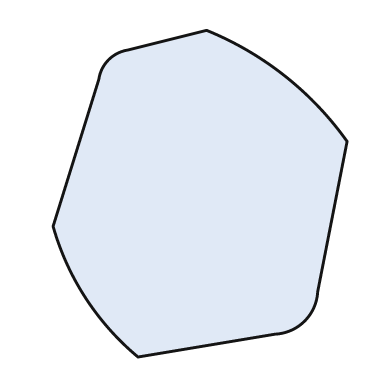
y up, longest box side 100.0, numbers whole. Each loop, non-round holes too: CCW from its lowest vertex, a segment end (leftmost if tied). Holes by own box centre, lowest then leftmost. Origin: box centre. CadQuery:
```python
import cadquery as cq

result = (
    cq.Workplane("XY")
    .moveTo(-19.0, -50.0)
    .lineTo(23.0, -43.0)
    .threePointArc((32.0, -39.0), (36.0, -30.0))
    .lineTo(45.0, 16.0)
    .threePointArc((26.0, 36.0), (2.0, 50.0))
    .lineTo(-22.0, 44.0)
    .threePointArc((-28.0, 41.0), (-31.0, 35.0))
    .lineTo(-45.0, -10.0)
    .threePointArc((-35.0, -32.0), (-19.0, -50.0))
    .close()
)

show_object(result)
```